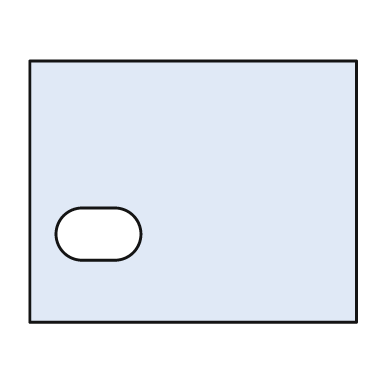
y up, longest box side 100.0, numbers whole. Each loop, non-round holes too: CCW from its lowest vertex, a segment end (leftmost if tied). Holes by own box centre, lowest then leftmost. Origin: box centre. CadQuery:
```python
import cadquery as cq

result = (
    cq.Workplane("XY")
    .moveTo(-50.0, -40.0)
    .lineTo(50.0, -40.0)
    .lineTo(50.0, 40.0)
    .lineTo(-50.0, 40.0)
    .close()
    .moveTo(-34.0, -21.0)
    .lineTo(-24.0, -21.0)
    .threePointArc((-16.0, -13.0), (-24.0, -5.0))
    .lineTo(-34.0, -5.0)
    .threePointArc((-42.0, -13.0), (-34.0, -21.0))
    .close()
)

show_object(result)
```